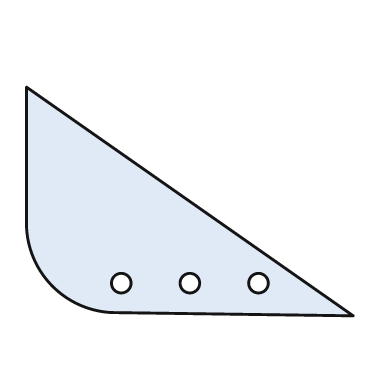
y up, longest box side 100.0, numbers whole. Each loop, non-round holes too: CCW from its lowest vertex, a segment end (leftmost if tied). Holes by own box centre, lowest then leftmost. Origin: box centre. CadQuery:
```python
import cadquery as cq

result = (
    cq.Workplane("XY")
    .moveTo(50.0, -35.0)
    .lineTo(-50.0, 35.0)
    .lineTo(-50.0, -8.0)
    .threePointArc((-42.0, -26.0), (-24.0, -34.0))
    .close()
    .moveTo(-21.0, -25.0)
    .circle(3.0)
    .moveTo(0.0, -25.0)
    .circle(3.0)
    .moveTo(21.0, -25.0)
    .circle(3.0)
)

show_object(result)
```